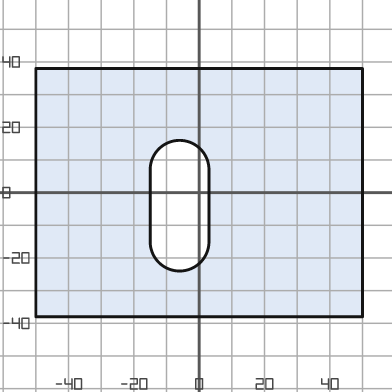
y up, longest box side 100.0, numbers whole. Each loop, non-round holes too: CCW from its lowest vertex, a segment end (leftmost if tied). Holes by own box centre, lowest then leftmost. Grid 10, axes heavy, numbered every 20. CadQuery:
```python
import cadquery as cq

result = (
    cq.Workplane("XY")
    .moveTo(-50.0, -38.0)
    .lineTo(50.0, -38.0)
    .lineTo(50.0, 38.0)
    .lineTo(-50.0, 38.0)
    .close()
    .moveTo(-15.0, -15.0)
    .threePointArc((-6.0, -24.0), (3.0, -15.0))
    .lineTo(3.0, 7.0)
    .threePointArc((-6.0, 16.0), (-15.0, 7.0))
    .close()
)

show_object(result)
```